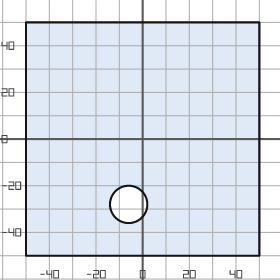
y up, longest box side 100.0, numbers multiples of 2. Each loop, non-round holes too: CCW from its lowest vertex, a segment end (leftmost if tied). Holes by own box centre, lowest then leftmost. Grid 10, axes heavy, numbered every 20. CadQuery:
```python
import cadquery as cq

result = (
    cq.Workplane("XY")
    .moveTo(-50.0, -50.0)
    .lineTo(50.0, -50.0)
    .lineTo(50.0, 50.0)
    .lineTo(-50.0, 50.0)
    .close()
    .moveTo(-6.0, -28.0)
    .circle(8.0)
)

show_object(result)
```